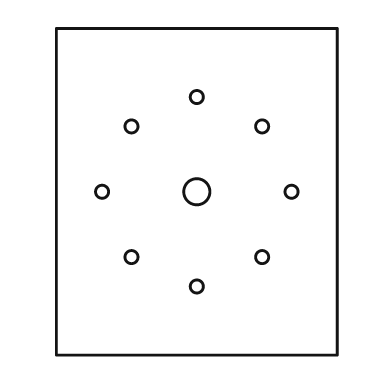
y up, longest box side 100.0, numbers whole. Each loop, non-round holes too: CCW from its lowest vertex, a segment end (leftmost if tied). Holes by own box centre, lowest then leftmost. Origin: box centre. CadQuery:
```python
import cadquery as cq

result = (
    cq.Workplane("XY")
    .moveTo(-43.0, -50.0)
    .lineTo(43.0, -50.0)
    .lineTo(43.0, 50.0)
    .lineTo(-43.0, 50.0)
    .close()
    .moveTo(0.0, -29.0)
    .circle(2.0)
    .moveTo(-20.0, -20.0)
    .circle(2.0)
    .moveTo(20.0, -20.0)
    .circle(2.0)
    .moveTo(-29.0, 0.0)
    .circle(2.0)
    .moveTo(0.0, 0.0)
    .circle(4.0)
    .moveTo(29.0, 0.0)
    .circle(2.0)
    .moveTo(-20.0, 20.0)
    .circle(2.0)
    .moveTo(20.0, 20.0)
    .circle(2.0)
    .moveTo(0.0, 29.0)
    .circle(2.0)
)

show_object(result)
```